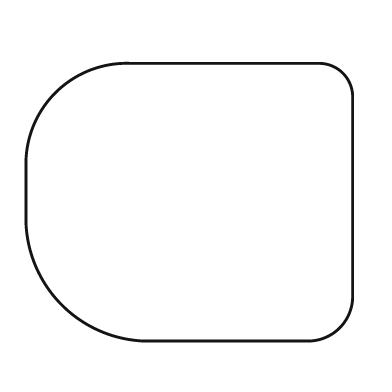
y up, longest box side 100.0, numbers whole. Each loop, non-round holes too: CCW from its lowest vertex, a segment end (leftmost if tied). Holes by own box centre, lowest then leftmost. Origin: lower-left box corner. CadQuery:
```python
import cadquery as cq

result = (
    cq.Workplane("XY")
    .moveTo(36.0, 0.0)
    .lineTo(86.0, 0.0)
    .threePointArc((96.0, 4.0), (100.0, 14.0))
    .lineTo(100.0, 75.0)
    .threePointArc((97.0, 82.0), (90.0, 85.0))
    .lineTo(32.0, 85.0)
    .threePointArc((9.0, 76.0), (0.0, 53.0))
    .lineTo(0.0, 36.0)
    .threePointArc((11.0, 11.0), (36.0, 0.0))
    .close()
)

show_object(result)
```